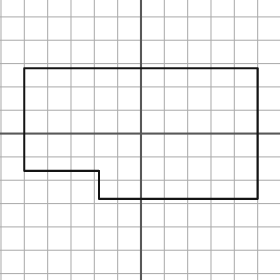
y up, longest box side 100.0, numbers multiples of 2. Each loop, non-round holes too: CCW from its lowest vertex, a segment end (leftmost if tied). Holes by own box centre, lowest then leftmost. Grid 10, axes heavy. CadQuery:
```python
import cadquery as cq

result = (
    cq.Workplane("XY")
    .moveTo(-18.0, -28.0)
    .lineTo(50.0, -28.0)
    .lineTo(50.0, 28.0)
    .lineTo(-50.0, 28.0)
    .lineTo(-50.0, -16.0)
    .lineTo(-18.0, -16.0)
    .close()
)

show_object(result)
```